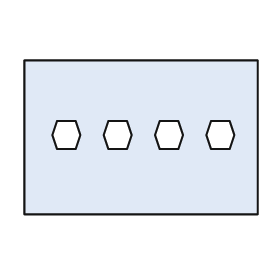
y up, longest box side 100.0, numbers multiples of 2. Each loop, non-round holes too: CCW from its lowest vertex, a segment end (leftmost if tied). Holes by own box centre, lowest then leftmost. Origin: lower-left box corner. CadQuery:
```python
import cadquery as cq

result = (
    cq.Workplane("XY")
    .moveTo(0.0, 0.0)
    .lineTo(100.0, 0.0)
    .lineTo(100.0, 66.0)
    .lineTo(0.0, 66.0)
    .close()
    .moveTo(14.0, 28.0)
    .lineTo(22.0, 28.0)
    .lineTo(24.0, 34.0)
    .lineTo(22.0, 40.0)
    .lineTo(14.0, 40.0)
    .lineTo(12.0, 34.0)
    .close()
    .moveTo(36.0, 28.0)
    .lineTo(44.0, 28.0)
    .lineTo(46.0, 34.0)
    .lineTo(44.0, 40.0)
    .lineTo(36.0, 40.0)
    .lineTo(34.0, 34.0)
    .close()
    .moveTo(58.0, 28.0)
    .lineTo(66.0, 28.0)
    .lineTo(68.0, 34.0)
    .lineTo(66.0, 40.0)
    .lineTo(58.0, 40.0)
    .lineTo(56.0, 34.0)
    .close()
    .moveTo(80.0, 28.0)
    .lineTo(88.0, 28.0)
    .lineTo(90.0, 34.0)
    .lineTo(88.0, 40.0)
    .lineTo(80.0, 40.0)
    .lineTo(78.0, 34.0)
    .close()
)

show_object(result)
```